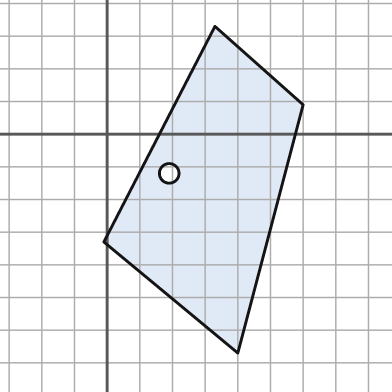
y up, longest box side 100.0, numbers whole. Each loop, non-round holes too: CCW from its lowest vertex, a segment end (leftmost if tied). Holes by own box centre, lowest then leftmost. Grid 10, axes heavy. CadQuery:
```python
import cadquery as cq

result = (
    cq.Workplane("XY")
    .moveTo(40.0, -67.0)
    .lineTo(60.0, 9.0)
    .lineTo(33.0, 33.0)
    .lineTo(-1.0, -33.0)
    .close()
    .moveTo(19.0, -12.0)
    .circle(3.0)
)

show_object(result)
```